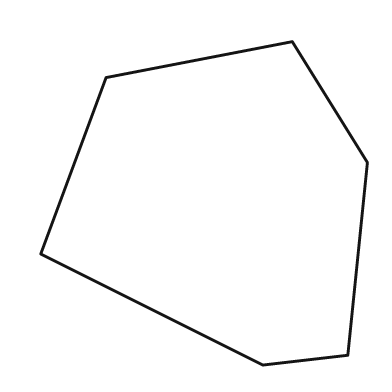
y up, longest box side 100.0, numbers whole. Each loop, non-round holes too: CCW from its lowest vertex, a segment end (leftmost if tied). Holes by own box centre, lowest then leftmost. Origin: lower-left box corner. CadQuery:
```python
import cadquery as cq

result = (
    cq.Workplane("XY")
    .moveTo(68.0, 0.0)
    .lineTo(94.0, 3.0)
    .lineTo(100.0, 62.0)
    .lineTo(77.0, 99.0)
    .lineTo(20.0, 88.0)
    .lineTo(0.0, 34.0)
    .close()
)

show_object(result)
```